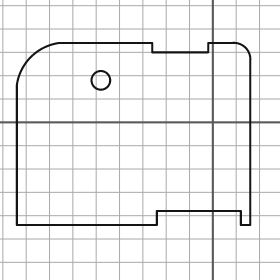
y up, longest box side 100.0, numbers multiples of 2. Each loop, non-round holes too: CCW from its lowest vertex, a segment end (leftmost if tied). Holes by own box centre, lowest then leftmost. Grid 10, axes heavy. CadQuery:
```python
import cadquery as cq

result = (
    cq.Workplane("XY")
    .moveTo(-84.0, -44.0)
    .lineTo(-24.0, -44.0)
    .lineTo(-24.0, -38.0)
    .lineTo(12.0, -38.0)
    .lineTo(12.0, -44.0)
    .lineTo(16.0, -44.0)
    .lineTo(16.0, 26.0)
    .threePointArc((14.0, 32.0), (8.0, 34.0))
    .lineTo(-2.0, 34.0)
    .lineTo(-2.0, 30.0)
    .lineTo(-26.0, 30.0)
    .lineTo(-26.0, 34.0)
    .lineTo(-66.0, 34.0)
    .threePointArc((-78.0, 28.0), (-84.0, 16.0))
    .close()
    .moveTo(-48.0, 18.0)
    .circle(4.0)
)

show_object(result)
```